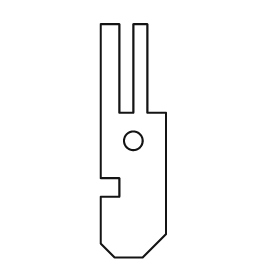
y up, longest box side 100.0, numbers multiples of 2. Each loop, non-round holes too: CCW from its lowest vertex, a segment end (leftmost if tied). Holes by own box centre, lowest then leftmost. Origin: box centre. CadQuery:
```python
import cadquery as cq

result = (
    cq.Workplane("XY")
    .moveTo(-8.0, -50.0)
    .lineTo(4.0, -50.0)
    .lineTo(14.0, -40.0)
    .lineTo(14.0, 12.0)
    .lineTo(6.0, 12.0)
    .lineTo(6.0, 50.0)
    .lineTo(0.0, 50.0)
    .lineTo(0.0, 12.0)
    .lineTo(-6.0, 12.0)
    .lineTo(-6.0, 50.0)
    .lineTo(-14.0, 50.0)
    .lineTo(-14.0, -16.0)
    .lineTo(-6.0, -16.0)
    .lineTo(-6.0, -24.0)
    .lineTo(-14.0, -24.0)
    .lineTo(-14.0, -44.0)
    .close()
    .moveTo(0.0, 0.0)
    .circle(4.0)
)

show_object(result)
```